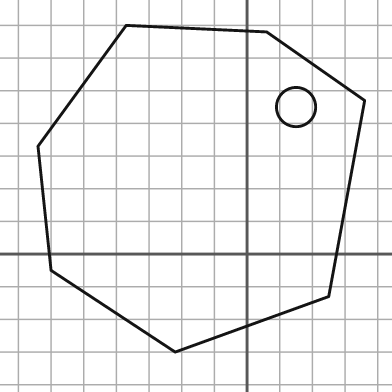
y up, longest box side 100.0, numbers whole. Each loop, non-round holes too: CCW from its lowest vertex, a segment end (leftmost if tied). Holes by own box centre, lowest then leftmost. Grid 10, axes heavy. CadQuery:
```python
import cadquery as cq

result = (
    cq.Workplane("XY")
    .moveTo(-22.0, -30.0)
    .lineTo(25.0, -13.0)
    .lineTo(36.0, 47.0)
    .lineTo(6.0, 68.0)
    .lineTo(-37.0, 70.0)
    .lineTo(-64.0, 33.0)
    .lineTo(-60.0, -5.0)
    .close()
    .moveTo(15.0, 45.0)
    .circle(6.0)
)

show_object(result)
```